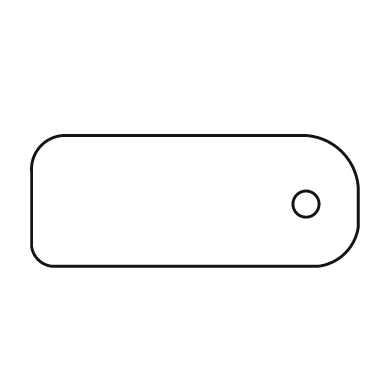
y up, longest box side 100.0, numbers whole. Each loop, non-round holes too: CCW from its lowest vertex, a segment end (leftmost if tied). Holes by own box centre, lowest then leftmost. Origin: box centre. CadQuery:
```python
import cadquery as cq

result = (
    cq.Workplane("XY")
    .moveTo(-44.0, -20.0)
    .lineTo(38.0, -20.0)
    .threePointArc((46.0, -16.0), (50.0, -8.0))
    .lineTo(50.0, 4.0)
    .threePointArc((45.0, 15.0), (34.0, 20.0))
    .lineTo(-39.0, 20.0)
    .threePointArc((-47.0, 17.0), (-50.0, 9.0))
    .lineTo(-50.0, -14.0)
    .threePointArc((-48.0, -18.0), (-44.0, -20.0))
    .close()
    .moveTo(34.0, -1.0)
    .circle(4.0)
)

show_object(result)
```